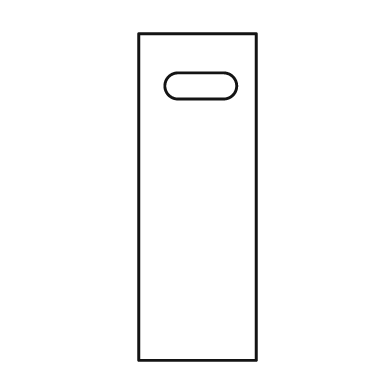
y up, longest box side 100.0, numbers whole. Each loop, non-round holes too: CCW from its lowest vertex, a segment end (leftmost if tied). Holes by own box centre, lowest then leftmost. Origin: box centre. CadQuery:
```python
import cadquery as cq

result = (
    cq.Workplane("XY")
    .moveTo(-18.0, -50.0)
    .lineTo(18.0, -50.0)
    .lineTo(18.0, 50.0)
    .lineTo(-18.0, 50.0)
    .close()
    .moveTo(-6.0, 30.0)
    .lineTo(8.0, 30.0)
    .threePointArc((12.0, 34.0), (8.0, 38.0))
    .lineTo(-6.0, 38.0)
    .threePointArc((-10.0, 34.0), (-6.0, 30.0))
    .close()
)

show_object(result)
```